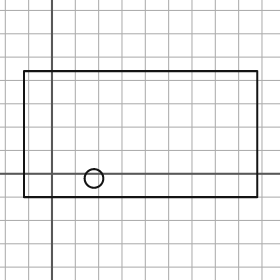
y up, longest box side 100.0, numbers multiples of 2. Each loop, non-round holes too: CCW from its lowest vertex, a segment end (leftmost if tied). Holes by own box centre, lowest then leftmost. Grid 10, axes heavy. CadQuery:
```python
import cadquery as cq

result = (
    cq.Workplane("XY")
    .moveTo(-12.0, -10.0)
    .lineTo(88.0, -10.0)
    .lineTo(88.0, 44.0)
    .lineTo(-12.0, 44.0)
    .close()
    .moveTo(18.0, -2.0)
    .circle(4.0)
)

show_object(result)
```